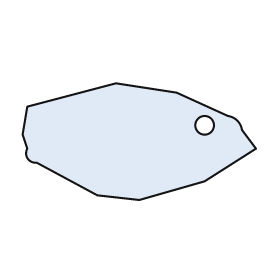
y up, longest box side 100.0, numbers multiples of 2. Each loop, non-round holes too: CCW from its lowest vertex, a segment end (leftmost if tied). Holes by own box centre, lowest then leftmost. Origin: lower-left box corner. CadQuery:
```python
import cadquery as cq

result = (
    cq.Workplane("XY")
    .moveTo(50.0, 0.0)
    .lineTo(78.0, 8.0)
    .lineTo(100.0, 22.0)
    .lineTo(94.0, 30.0)
    .threePointArc((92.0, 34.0), (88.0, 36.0))
    .lineTo(66.0, 46.0)
    .lineTo(40.0, 50.0)
    .lineTo(2.0, 40.0)
    .lineTo(0.0, 28.0)
    .lineTo(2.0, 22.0)
    .threePointArc((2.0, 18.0), (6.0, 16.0))
    .lineTo(32.0, 2.0)
    .close()
    .moveTo(78.0, 32.0)
    .circle(4.0)
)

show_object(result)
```